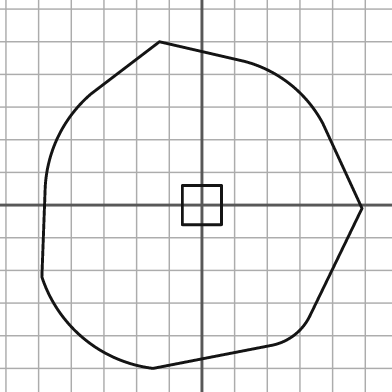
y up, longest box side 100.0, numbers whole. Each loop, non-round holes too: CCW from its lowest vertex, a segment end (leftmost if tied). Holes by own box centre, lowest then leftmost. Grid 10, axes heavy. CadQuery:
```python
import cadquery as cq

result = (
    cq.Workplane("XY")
    .moveTo(-15.0, -50.0)
    .lineTo(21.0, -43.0)
    .threePointArc((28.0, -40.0), (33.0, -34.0))
    .lineTo(49.0, -1.0)
    .lineTo(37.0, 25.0)
    .threePointArc((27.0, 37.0), (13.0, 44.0))
    .lineTo(-13.0, 50.0)
    .lineTo(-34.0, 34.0)
    .threePointArc((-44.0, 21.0), (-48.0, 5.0))
    .lineTo(-49.0, -22.0)
    .threePointArc((-36.0, -41.0), (-15.0, -50.0))
    .close()
    .moveTo(-6.0, -6.0)
    .lineTo(6.0, -6.0)
    .lineTo(6.0, 6.0)
    .lineTo(-6.0, 6.0)
    .close()
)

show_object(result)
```